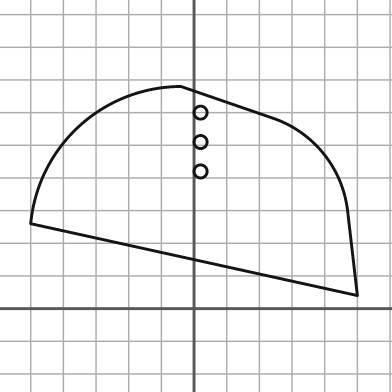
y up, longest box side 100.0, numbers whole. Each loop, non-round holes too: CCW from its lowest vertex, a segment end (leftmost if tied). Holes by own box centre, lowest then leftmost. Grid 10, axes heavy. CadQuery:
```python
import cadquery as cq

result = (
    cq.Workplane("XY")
    .moveTo(50.0, 4.0)
    .lineTo(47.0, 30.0)
    .threePointArc((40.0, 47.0), (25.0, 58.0))
    .lineTo(-4.0, 68.0)
    .threePointArc((-35.0, 56.0), (-50.0, 26.0))
    .close()
    .moveTo(2.0, 42.0)
    .circle(2.0)
    .moveTo(2.0, 51.0)
    .circle(2.0)
    .moveTo(2.0, 60.0)
    .circle(2.0)
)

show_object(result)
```